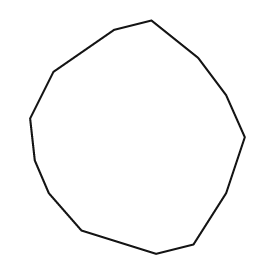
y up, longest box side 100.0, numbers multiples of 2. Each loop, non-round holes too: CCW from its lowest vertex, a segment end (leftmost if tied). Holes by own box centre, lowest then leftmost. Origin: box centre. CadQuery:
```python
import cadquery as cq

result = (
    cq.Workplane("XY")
    .moveTo(8.0, -50.0)
    .lineTo(24.0, -46.0)
    .lineTo(38.0, -24.0)
    .lineTo(46.0, 0.0)
    .lineTo(38.0, 18.0)
    .lineTo(26.0, 34.0)
    .lineTo(6.0, 50.0)
    .lineTo(-10.0, 46.0)
    .lineTo(-36.0, 28.0)
    .lineTo(-46.0, 8.0)
    .lineTo(-44.0, -10.0)
    .lineTo(-38.0, -24.0)
    .lineTo(-24.0, -40.0)
    .close()
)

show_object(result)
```